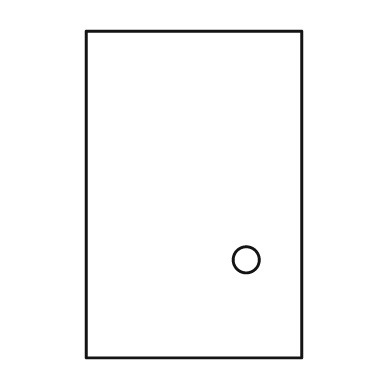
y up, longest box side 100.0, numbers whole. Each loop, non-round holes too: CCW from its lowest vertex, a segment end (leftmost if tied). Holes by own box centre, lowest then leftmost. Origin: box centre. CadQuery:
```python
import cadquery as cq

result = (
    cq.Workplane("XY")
    .moveTo(-33.0, -50.0)
    .lineTo(33.0, -50.0)
    .lineTo(33.0, 50.0)
    .lineTo(-33.0, 50.0)
    .close()
    .moveTo(16.0, -20.0)
    .circle(4.0)
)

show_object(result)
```